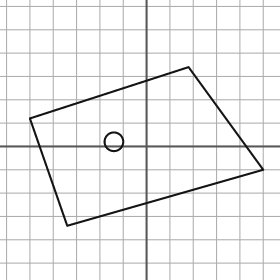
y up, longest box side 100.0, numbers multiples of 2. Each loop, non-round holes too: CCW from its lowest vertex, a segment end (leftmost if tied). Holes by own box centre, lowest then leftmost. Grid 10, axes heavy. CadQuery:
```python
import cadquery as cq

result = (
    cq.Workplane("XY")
    .moveTo(-34.0, -34.0)
    .lineTo(50.0, -10.0)
    .lineTo(18.0, 34.0)
    .lineTo(-50.0, 12.0)
    .close()
    .moveTo(-14.0, 2.0)
    .circle(4.0)
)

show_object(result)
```